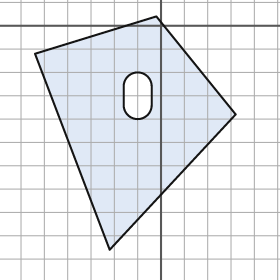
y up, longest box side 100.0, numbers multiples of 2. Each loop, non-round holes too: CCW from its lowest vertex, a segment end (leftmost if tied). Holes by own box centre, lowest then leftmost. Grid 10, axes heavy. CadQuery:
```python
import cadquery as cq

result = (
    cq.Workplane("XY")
    .moveTo(-22.0, -96.0)
    .lineTo(32.0, -38.0)
    .lineTo(-2.0, 4.0)
    .lineTo(-54.0, -12.0)
    .close()
    .moveTo(-16.0, -34.0)
    .threePointArc((-10.0, -40.0), (-4.0, -34.0))
    .lineTo(-4.0, -26.0)
    .threePointArc((-10.0, -20.0), (-16.0, -26.0))
    .close()
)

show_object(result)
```